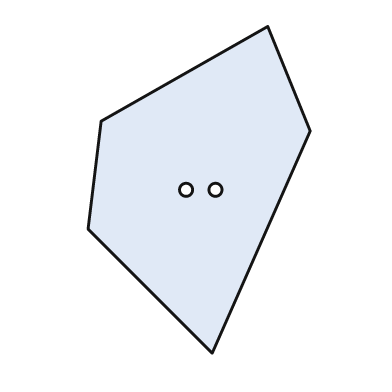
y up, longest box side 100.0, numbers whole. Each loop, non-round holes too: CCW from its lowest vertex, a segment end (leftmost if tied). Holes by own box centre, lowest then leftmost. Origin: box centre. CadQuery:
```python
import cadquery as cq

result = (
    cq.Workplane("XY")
    .moveTo(4.0, -50.0)
    .lineTo(34.0, 18.0)
    .lineTo(21.0, 50.0)
    .lineTo(-30.0, 21.0)
    .lineTo(-34.0, -12.0)
    .close()
    .moveTo(-4.0, 0.0)
    .circle(2.0)
    .moveTo(5.0, 0.0)
    .circle(2.0)
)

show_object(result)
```